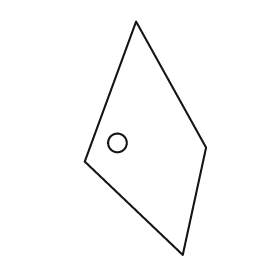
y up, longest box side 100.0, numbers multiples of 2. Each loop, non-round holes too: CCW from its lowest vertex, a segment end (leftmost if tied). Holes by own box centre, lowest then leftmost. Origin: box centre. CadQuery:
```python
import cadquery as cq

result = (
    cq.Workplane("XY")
    .moveTo(16.0, -50.0)
    .lineTo(26.0, -4.0)
    .lineTo(-4.0, 50.0)
    .lineTo(-26.0, -10.0)
    .close()
    .moveTo(-12.0, -2.0)
    .circle(4.0)
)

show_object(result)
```